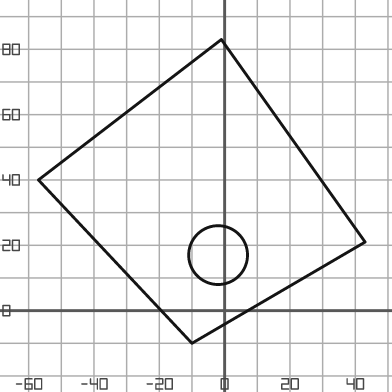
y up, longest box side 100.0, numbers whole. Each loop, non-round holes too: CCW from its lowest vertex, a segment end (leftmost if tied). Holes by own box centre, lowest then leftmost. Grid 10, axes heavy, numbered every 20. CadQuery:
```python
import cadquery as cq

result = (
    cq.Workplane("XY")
    .moveTo(-10.0, -10.0)
    .lineTo(43.0, 21.0)
    .lineTo(-1.0, 83.0)
    .lineTo(-57.0, 40.0)
    .close()
    .moveTo(-2.0, 17.0)
    .circle(9.0)
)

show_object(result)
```